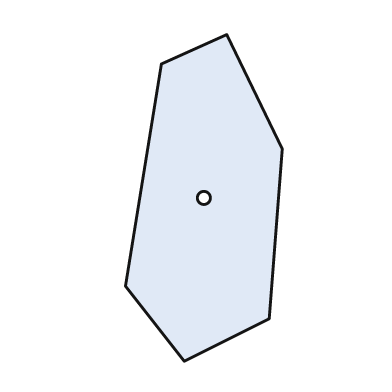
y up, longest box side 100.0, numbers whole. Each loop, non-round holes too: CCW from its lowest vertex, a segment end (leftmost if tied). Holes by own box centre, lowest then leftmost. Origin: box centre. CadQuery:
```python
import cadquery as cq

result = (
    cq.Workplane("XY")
    .moveTo(-6.0, -50.0)
    .lineTo(20.0, -37.0)
    .lineTo(24.0, 15.0)
    .lineTo(7.0, 50.0)
    .lineTo(-13.0, 41.0)
    .lineTo(-24.0, -27.0)
    .close()
    .moveTo(0.0, 0.0)
    .circle(2.0)
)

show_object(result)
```